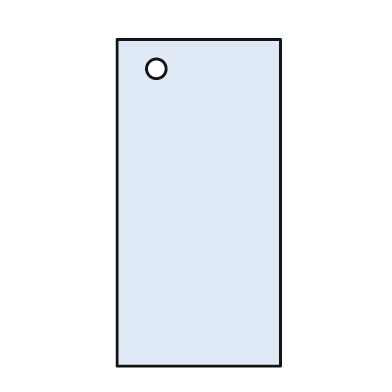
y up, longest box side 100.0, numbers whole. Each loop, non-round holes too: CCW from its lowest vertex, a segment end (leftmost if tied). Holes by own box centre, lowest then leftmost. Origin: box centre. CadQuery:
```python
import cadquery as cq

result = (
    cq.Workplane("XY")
    .moveTo(-25.0, -50.0)
    .lineTo(25.0, -50.0)
    .lineTo(25.0, 50.0)
    .lineTo(-25.0, 50.0)
    .close()
    .moveTo(-13.0, 41.0)
    .circle(3.0)
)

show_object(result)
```